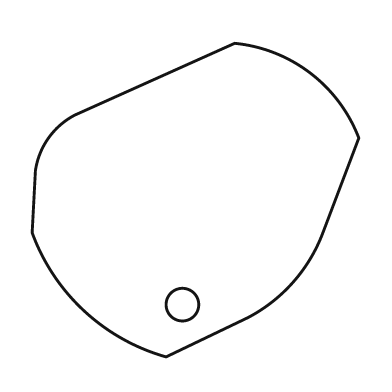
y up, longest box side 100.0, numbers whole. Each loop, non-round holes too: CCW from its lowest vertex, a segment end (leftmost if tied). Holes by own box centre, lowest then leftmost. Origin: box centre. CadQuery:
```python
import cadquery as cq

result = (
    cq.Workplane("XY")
    .moveTo(-9.0, -48.0)
    .lineTo(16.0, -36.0)
    .threePointArc((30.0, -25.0), (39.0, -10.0))
    .lineTo(50.0, 19.0)
    .threePointArc((35.0, 39.0), (12.0, 48.0))
    .lineTo(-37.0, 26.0)
    .threePointArc((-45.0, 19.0), (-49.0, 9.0))
    .lineTo(-50.0, -10.0)
    .threePointArc((-34.0, -34.0), (-9.0, -48.0))
    .close()
    .moveTo(-4.0, -32.0)
    .circle(5.0)
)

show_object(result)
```